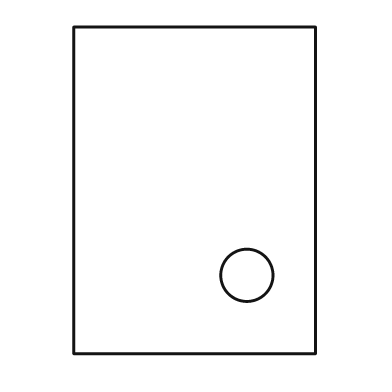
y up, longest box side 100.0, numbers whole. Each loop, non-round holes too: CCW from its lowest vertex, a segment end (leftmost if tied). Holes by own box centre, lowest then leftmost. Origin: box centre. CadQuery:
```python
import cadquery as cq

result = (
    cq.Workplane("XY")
    .moveTo(-37.0, -50.0)
    .lineTo(37.0, -50.0)
    .lineTo(37.0, 50.0)
    .lineTo(-37.0, 50.0)
    .close()
    .moveTo(16.0, -26.0)
    .circle(8.0)
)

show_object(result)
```